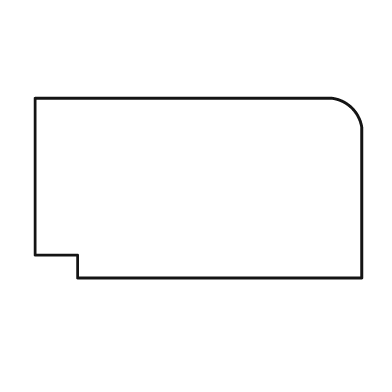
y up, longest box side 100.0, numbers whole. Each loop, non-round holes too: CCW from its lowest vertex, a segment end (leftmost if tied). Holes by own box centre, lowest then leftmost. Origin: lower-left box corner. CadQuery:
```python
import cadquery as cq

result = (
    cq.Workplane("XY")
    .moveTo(13.0, 0.0)
    .lineTo(100.0, 0.0)
    .lineTo(100.0, 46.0)
    .threePointArc((97.0, 52.0), (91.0, 55.0))
    .lineTo(0.0, 55.0)
    .lineTo(0.0, 7.0)
    .lineTo(13.0, 7.0)
    .close()
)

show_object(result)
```